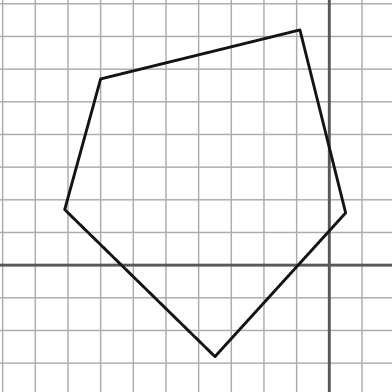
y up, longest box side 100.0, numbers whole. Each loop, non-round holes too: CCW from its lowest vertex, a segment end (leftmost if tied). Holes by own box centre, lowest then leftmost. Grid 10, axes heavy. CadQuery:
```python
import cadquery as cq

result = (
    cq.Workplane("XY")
    .moveTo(-35.0, -28.0)
    .lineTo(5.0, 16.0)
    .lineTo(-9.0, 72.0)
    .lineTo(-70.0, 57.0)
    .lineTo(-81.0, 17.0)
    .close()
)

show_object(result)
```